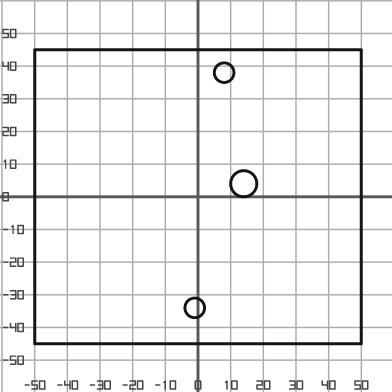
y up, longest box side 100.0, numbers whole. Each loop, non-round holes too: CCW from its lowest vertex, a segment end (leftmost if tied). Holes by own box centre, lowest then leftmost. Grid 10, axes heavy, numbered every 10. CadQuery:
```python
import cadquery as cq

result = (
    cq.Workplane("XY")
    .moveTo(-50.0, -45.0)
    .lineTo(50.0, -45.0)
    .lineTo(50.0, 45.0)
    .lineTo(-50.0, 45.0)
    .close()
    .moveTo(-1.0, -34.0)
    .circle(3.0)
    .moveTo(14.0, 4.0)
    .circle(4.0)
    .moveTo(8.0, 38.0)
    .circle(3.0)
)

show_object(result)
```